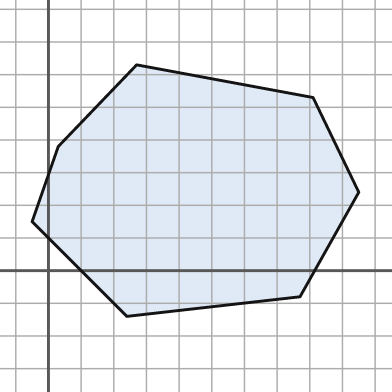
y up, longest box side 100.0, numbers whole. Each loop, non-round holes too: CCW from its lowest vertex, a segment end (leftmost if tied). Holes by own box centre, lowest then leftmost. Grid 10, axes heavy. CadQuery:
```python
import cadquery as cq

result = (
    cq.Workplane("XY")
    .moveTo(24.0, -14.0)
    .lineTo(77.0, -8.0)
    .lineTo(95.0, 24.0)
    .lineTo(81.0, 53.0)
    .lineTo(27.0, 63.0)
    .lineTo(3.0, 38.0)
    .lineTo(-5.0, 15.0)
    .close()
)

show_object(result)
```